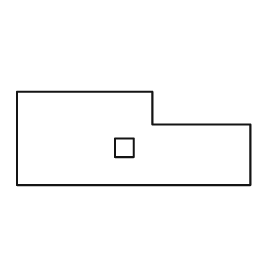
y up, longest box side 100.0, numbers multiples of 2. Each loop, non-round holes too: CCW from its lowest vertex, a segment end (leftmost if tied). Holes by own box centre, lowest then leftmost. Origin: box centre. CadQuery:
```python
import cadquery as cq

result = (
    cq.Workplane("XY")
    .moveTo(-50.0, -20.0)
    .lineTo(50.0, -20.0)
    .lineTo(50.0, 6.0)
    .lineTo(8.0, 6.0)
    .lineTo(8.0, 20.0)
    .lineTo(-50.0, 20.0)
    .close()
    .moveTo(-8.0, -8.0)
    .lineTo(0.0, -8.0)
    .lineTo(0.0, 0.0)
    .lineTo(-8.0, 0.0)
    .close()
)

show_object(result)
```